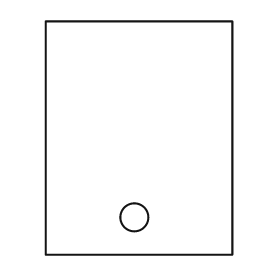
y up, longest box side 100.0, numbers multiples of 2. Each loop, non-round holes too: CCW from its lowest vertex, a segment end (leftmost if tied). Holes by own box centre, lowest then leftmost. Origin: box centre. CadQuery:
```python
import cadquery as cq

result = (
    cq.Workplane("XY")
    .moveTo(-40.0, -50.0)
    .lineTo(40.0, -50.0)
    .lineTo(40.0, 50.0)
    .lineTo(-40.0, 50.0)
    .close()
    .moveTo(-2.0, -34.0)
    .circle(6.0)
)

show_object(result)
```